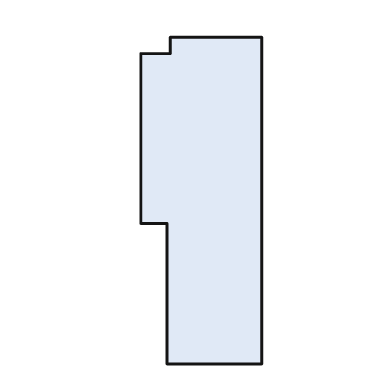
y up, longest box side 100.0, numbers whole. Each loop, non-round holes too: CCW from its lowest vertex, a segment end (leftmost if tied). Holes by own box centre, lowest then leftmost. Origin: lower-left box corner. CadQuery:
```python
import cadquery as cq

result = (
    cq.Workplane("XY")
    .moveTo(8.0, 0.0)
    .lineTo(37.0, 0.0)
    .lineTo(37.0, 100.0)
    .lineTo(9.0, 100.0)
    .lineTo(9.0, 95.0)
    .lineTo(0.0, 95.0)
    .lineTo(0.0, 43.0)
    .lineTo(8.0, 43.0)
    .close()
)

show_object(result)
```